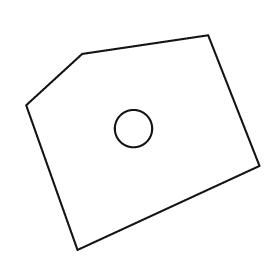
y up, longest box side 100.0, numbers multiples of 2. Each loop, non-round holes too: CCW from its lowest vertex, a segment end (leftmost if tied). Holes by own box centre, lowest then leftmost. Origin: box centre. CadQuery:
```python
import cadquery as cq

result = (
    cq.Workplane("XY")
    .moveTo(-28.0, -46.0)
    .lineTo(50.0, -10.0)
    .lineTo(28.0, 46.0)
    .lineTo(-26.0, 38.0)
    .lineTo(-50.0, 16.0)
    .close()
    .moveTo(-4.0, 6.0)
    .circle(8.0)
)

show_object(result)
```